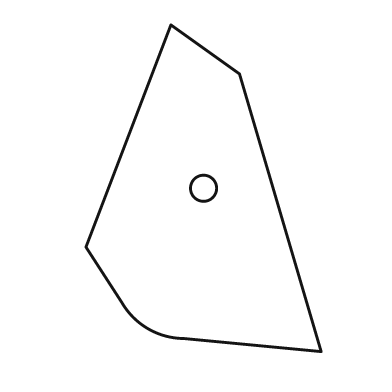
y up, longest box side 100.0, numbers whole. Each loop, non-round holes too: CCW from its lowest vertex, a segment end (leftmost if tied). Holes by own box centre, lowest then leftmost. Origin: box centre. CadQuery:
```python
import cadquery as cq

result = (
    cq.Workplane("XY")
    .moveTo(36.0, -50.0)
    .lineTo(11.0, 35.0)
    .lineTo(-10.0, 50.0)
    .lineTo(-36.0, -18.0)
    .lineTo(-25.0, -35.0)
    .threePointArc((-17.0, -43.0), (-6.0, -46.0))
    .close()
    .moveTo(0.0, 0.0)
    .circle(4.0)
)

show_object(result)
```